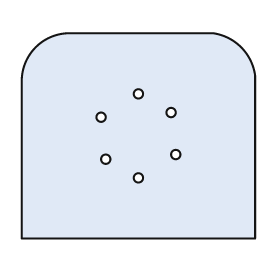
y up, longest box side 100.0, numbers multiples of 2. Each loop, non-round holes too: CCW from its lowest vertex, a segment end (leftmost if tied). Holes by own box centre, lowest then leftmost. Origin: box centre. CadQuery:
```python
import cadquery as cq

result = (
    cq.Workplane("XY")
    .moveTo(-50.0, -44.0)
    .lineTo(50.0, -44.0)
    .lineTo(50.0, 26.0)
    .threePointArc((44.0, 38.0), (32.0, 44.0))
    .lineTo(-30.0, 44.0)
    .threePointArc((-44.0, 38.0), (-50.0, 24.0))
    .close()
    .moveTo(0.0, -18.0)
    .circle(2.0)
    .moveTo(-14.0, -10.0)
    .circle(2.0)
    .moveTo(16.0, -8.0)
    .circle(2.0)
    .moveTo(-16.0, 8.0)
    .circle(2.0)
    .moveTo(14.0, 10.0)
    .circle(2.0)
    .moveTo(0.0, 18.0)
    .circle(2.0)
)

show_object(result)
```